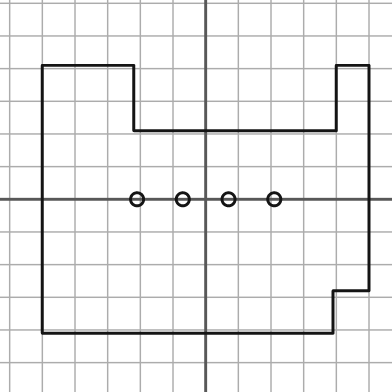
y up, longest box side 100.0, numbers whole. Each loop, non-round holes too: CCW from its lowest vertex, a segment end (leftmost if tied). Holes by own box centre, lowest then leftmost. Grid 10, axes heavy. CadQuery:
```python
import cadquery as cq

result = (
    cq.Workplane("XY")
    .moveTo(-50.0, -41.0)
    .lineTo(39.0, -41.0)
    .lineTo(39.0, -28.0)
    .lineTo(50.0, -28.0)
    .lineTo(50.0, 41.0)
    .lineTo(40.0, 41.0)
    .lineTo(40.0, 21.0)
    .lineTo(-22.0, 21.0)
    .lineTo(-22.0, 41.0)
    .lineTo(-50.0, 41.0)
    .close()
    .moveTo(-21.0, 0.0)
    .circle(2.0)
    .moveTo(-7.0, 0.0)
    .circle(2.0)
    .moveTo(7.0, 0.0)
    .circle(2.0)
    .moveTo(21.0, 0.0)
    .circle(2.0)
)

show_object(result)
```